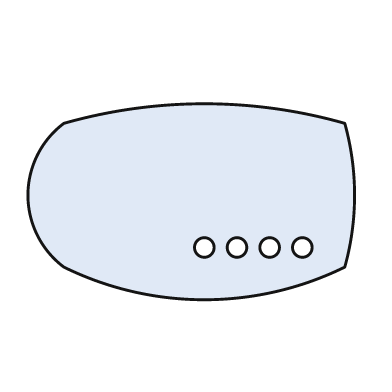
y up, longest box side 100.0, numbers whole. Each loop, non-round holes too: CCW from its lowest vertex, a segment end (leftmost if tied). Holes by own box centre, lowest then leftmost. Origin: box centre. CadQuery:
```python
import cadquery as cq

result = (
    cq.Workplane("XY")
    .moveTo(-39.0, -20.0)
    .threePointArc((4.0, -30.0), (47.0, -20.0))
    .threePointArc((50.0, 2.0), (47.0, 24.0))
    .threePointArc((4.0, 30.0), (-39.0, 24.0))
    .threePointArc((-50.0, 2.0), (-39.0, -20.0))
    .close()
    .moveTo(4.0, -14.0)
    .circle(3.0)
    .moveTo(14.0, -14.0)
    .circle(3.0)
    .moveTo(24.0, -14.0)
    .circle(3.0)
    .moveTo(34.0, -14.0)
    .circle(3.0)
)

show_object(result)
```